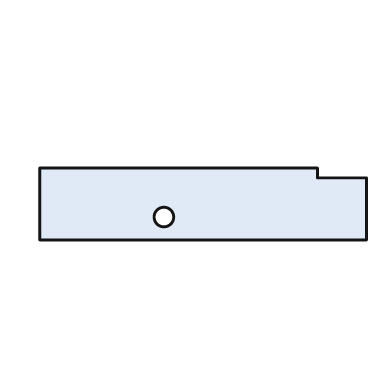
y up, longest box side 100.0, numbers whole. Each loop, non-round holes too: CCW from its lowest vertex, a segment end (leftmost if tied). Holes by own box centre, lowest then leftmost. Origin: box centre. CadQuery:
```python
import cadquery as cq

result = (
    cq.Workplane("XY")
    .moveTo(-50.0, -11.0)
    .lineTo(50.0, -11.0)
    .lineTo(50.0, 8.0)
    .lineTo(35.0, 8.0)
    .lineTo(35.0, 11.0)
    .lineTo(-50.0, 11.0)
    .close()
    .moveTo(-12.0, -4.0)
    .circle(3.0)
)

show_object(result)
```